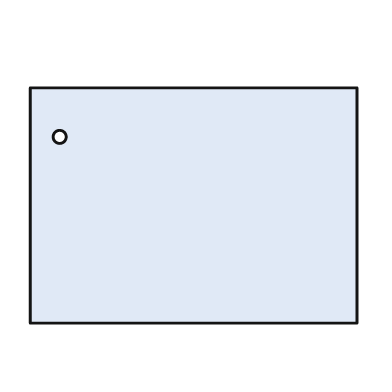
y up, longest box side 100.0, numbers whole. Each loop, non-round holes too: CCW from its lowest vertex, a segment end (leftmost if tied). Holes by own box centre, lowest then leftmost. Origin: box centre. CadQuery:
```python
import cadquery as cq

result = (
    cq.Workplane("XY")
    .moveTo(-50.0, -36.0)
    .lineTo(50.0, -36.0)
    .lineTo(50.0, 36.0)
    .lineTo(-50.0, 36.0)
    .close()
    .moveTo(-41.0, 21.0)
    .circle(2.0)
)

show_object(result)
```